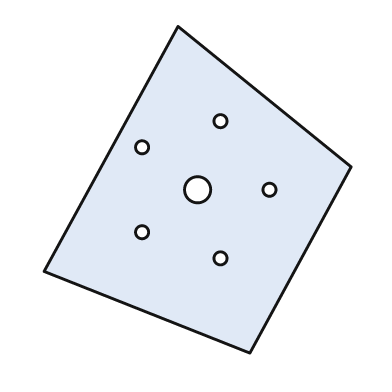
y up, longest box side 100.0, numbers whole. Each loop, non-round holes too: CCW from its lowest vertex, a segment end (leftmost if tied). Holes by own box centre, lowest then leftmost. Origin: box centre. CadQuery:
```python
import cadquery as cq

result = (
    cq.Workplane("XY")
    .moveTo(16.0, -50.0)
    .lineTo(47.0, 7.0)
    .lineTo(-6.0, 50.0)
    .lineTo(-47.0, -25.0)
    .close()
    .moveTo(7.0, -21.0)
    .circle(2.0)
    .moveTo(-17.0, -13.0)
    .circle(2.0)
    .moveTo(0.0, 0.0)
    .circle(4.0)
    .moveTo(22.0, 0.0)
    .circle(2.0)
    .moveTo(-17.0, 13.0)
    .circle(2.0)
    .moveTo(7.0, 21.0)
    .circle(2.0)
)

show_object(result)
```